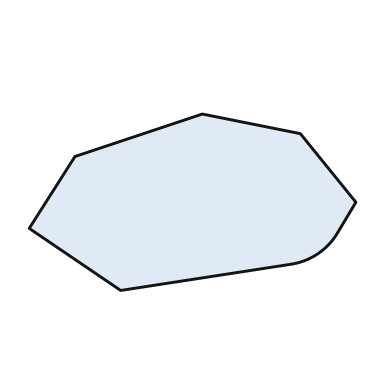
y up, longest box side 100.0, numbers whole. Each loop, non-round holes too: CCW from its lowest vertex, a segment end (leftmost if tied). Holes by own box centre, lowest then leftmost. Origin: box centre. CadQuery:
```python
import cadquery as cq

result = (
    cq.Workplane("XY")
    .moveTo(-22.0, -27.0)
    .lineTo(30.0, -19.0)
    .threePointArc((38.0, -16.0), (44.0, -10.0))
    .lineTo(50.0, 0.0)
    .lineTo(33.0, 21.0)
    .lineTo(3.0, 27.0)
    .lineTo(-36.0, 14.0)
    .lineTo(-50.0, -8.0)
    .close()
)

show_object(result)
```